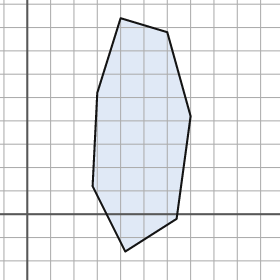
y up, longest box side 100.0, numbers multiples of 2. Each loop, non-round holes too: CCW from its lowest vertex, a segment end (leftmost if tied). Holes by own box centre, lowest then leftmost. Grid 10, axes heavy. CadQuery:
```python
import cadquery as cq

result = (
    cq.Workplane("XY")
    .moveTo(42.0, -16.0)
    .lineTo(64.0, -2.0)
    .lineTo(70.0, 42.0)
    .lineTo(60.0, 78.0)
    .lineTo(40.0, 84.0)
    .lineTo(30.0, 52.0)
    .lineTo(28.0, 12.0)
    .close()
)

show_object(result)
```